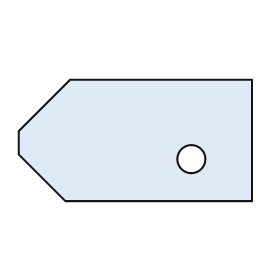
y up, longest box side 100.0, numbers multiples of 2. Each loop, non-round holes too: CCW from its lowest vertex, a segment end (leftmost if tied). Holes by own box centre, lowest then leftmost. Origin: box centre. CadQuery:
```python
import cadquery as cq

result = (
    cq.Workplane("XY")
    .moveTo(-30.0, -26.0)
    .lineTo(50.0, -26.0)
    .lineTo(50.0, 26.0)
    .lineTo(-28.0, 26.0)
    .lineTo(-50.0, 4.0)
    .lineTo(-50.0, -6.0)
    .close()
    .moveTo(24.0, -8.0)
    .circle(6.0)
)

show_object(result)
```